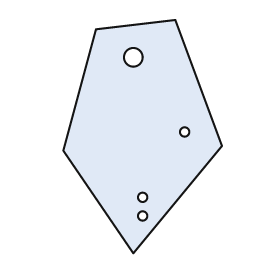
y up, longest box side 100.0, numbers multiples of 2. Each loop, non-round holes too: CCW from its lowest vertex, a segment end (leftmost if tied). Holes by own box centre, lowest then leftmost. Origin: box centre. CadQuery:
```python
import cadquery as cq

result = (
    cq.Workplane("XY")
    .moveTo(-4.0, -50.0)
    .lineTo(34.0, -4.0)
    .lineTo(14.0, 50.0)
    .lineTo(-20.0, 46.0)
    .lineTo(-34.0, -6.0)
    .close()
    .moveTo(0.0, -34.0)
    .circle(2.0)
    .moveTo(0.0, -26.0)
    .circle(2.0)
    .moveTo(18.0, 2.0)
    .circle(2.0)
    .moveTo(-4.0, 34.0)
    .circle(4.0)
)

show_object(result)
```